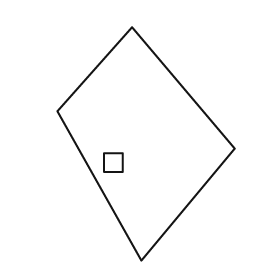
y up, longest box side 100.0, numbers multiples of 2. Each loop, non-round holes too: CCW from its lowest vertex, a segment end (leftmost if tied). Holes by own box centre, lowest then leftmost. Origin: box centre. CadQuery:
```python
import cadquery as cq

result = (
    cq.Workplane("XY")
    .moveTo(-2.0, -50.0)
    .lineTo(38.0, -2.0)
    .lineTo(-6.0, 50.0)
    .lineTo(-38.0, 14.0)
    .close()
    .moveTo(-18.0, -12.0)
    .lineTo(-10.0, -12.0)
    .lineTo(-10.0, -4.0)
    .lineTo(-18.0, -4.0)
    .close()
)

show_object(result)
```